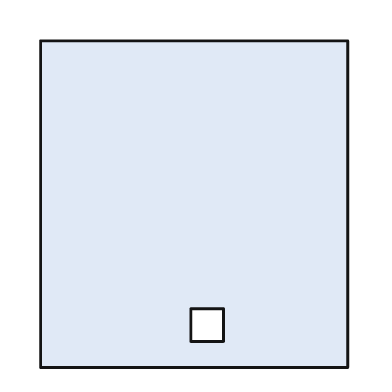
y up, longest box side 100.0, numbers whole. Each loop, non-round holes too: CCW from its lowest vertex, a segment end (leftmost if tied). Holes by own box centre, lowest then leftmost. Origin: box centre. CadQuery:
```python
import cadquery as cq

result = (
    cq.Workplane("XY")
    .moveTo(-47.0, -50.0)
    .lineTo(47.0, -50.0)
    .lineTo(47.0, 50.0)
    .lineTo(-47.0, 50.0)
    .close()
    .moveTo(-1.0, -42.0)
    .lineTo(9.0, -42.0)
    .lineTo(9.0, -32.0)
    .lineTo(-1.0, -32.0)
    .close()
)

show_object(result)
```